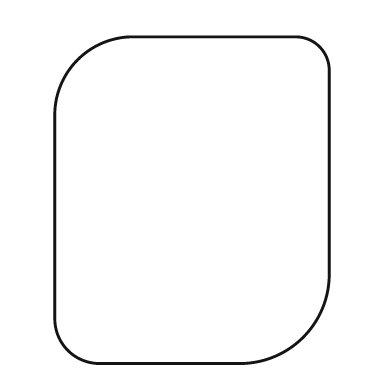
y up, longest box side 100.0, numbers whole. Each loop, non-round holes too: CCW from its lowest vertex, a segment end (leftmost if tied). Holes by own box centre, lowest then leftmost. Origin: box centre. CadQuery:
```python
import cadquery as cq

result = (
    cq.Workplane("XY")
    .moveTo(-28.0, -50.0)
    .lineTo(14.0, -50.0)
    .threePointArc((34.0, -42.0), (42.0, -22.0))
    .lineTo(42.0, 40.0)
    .threePointArc((39.0, 47.0), (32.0, 50.0))
    .lineTo(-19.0, 50.0)
    .threePointArc((-35.0, 43.0), (-42.0, 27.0))
    .lineTo(-42.0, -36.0)
    .threePointArc((-38.0, -46.0), (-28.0, -50.0))
    .close()
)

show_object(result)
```